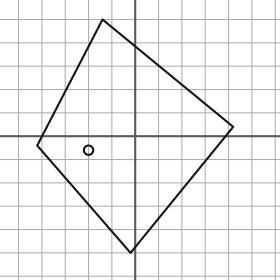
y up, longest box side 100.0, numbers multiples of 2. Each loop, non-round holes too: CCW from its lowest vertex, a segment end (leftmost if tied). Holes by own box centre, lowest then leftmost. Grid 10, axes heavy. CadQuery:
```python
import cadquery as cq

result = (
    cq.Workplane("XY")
    .moveTo(-2.0, -50.0)
    .lineTo(42.0, 4.0)
    .lineTo(-14.0, 50.0)
    .lineTo(-42.0, -4.0)
    .close()
    .moveTo(-20.0, -6.0)
    .circle(2.0)
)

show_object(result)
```